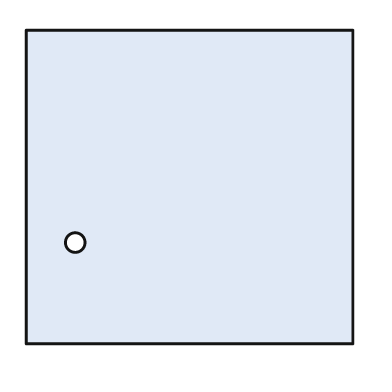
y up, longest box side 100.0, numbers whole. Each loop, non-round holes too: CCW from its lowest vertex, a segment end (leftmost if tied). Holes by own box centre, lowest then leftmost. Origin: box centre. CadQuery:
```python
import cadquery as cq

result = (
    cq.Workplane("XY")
    .moveTo(-50.0, -48.0)
    .lineTo(50.0, -48.0)
    .lineTo(50.0, 48.0)
    .lineTo(-50.0, 48.0)
    .close()
    .moveTo(-35.0, -17.0)
    .circle(3.0)
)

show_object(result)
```